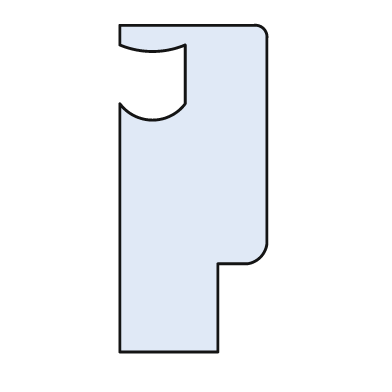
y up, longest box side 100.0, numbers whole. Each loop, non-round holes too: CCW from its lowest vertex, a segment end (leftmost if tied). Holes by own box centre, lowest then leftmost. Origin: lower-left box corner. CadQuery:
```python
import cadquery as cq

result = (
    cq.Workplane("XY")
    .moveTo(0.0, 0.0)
    .lineTo(30.0, 0.0)
    .lineTo(30.0, 27.0)
    .lineTo(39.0, 27.0)
    .threePointArc((43.0, 29.0), (45.0, 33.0))
    .lineTo(45.0, 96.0)
    .threePointArc((44.0, 99.0), (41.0, 100.0))
    .lineTo(0.0, 100.0)
    .lineTo(0.0, 94.0)
    .threePointArc((10.0, 92.0), (20.0, 94.0))
    .lineTo(20.0, 76.0)
    .threePointArc((10.0, 71.0), (0.0, 76.0))
    .close()
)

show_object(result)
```